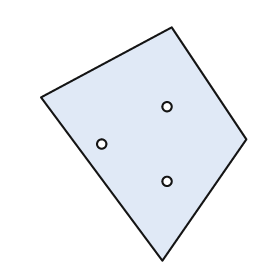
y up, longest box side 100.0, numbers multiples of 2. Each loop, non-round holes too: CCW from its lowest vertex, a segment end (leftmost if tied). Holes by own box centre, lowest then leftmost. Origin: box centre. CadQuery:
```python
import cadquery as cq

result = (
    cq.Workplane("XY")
    .moveTo(8.0, -50.0)
    .lineTo(44.0, 2.0)
    .lineTo(12.0, 50.0)
    .lineTo(-44.0, 20.0)
    .close()
    .moveTo(10.0, -16.0)
    .circle(2.0)
    .moveTo(-18.0, 0.0)
    .circle(2.0)
    .moveTo(10.0, 16.0)
    .circle(2.0)
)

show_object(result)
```